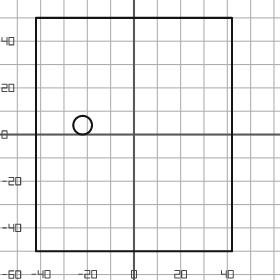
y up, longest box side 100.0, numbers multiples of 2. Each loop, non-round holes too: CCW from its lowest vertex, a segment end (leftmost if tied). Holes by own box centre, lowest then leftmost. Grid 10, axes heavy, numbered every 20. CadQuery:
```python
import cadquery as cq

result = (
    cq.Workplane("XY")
    .moveTo(-42.0, -50.0)
    .lineTo(42.0, -50.0)
    .lineTo(42.0, 50.0)
    .lineTo(-42.0, 50.0)
    .close()
    .moveTo(-22.0, 4.0)
    .circle(4.0)
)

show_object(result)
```